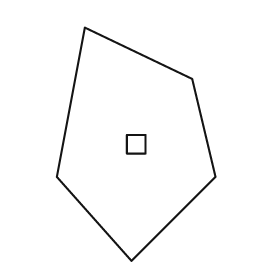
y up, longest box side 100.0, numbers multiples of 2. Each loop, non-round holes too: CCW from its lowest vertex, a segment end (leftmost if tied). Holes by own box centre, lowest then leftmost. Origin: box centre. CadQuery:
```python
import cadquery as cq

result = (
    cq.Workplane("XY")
    .moveTo(-2.0, -50.0)
    .lineTo(34.0, -14.0)
    .lineTo(24.0, 28.0)
    .lineTo(-22.0, 50.0)
    .lineTo(-34.0, -14.0)
    .close()
    .moveTo(-4.0, -4.0)
    .lineTo(4.0, -4.0)
    .lineTo(4.0, 4.0)
    .lineTo(-4.0, 4.0)
    .close()
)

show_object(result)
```